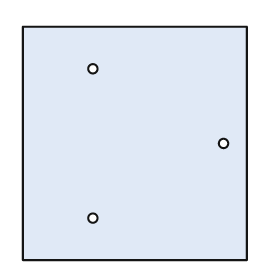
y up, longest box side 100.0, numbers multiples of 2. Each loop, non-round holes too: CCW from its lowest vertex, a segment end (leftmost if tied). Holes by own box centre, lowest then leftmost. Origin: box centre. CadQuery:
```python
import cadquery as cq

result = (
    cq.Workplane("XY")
    .moveTo(-48.0, -50.0)
    .lineTo(48.0, -50.0)
    .lineTo(48.0, 50.0)
    .lineTo(-48.0, 50.0)
    .close()
    .moveTo(-18.0, -32.0)
    .circle(2.0)
    .moveTo(38.0, 0.0)
    .circle(2.0)
    .moveTo(-18.0, 32.0)
    .circle(2.0)
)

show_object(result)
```